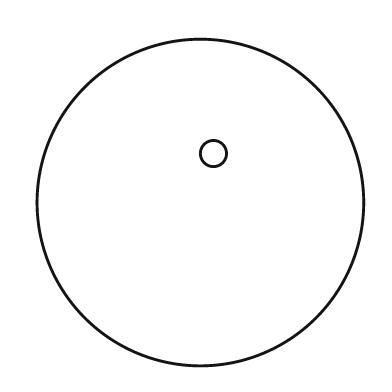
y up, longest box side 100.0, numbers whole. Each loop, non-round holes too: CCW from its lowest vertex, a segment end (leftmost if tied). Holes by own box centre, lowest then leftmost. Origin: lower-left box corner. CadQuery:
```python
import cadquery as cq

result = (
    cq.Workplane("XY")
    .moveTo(50.0, 50.0)
    .circle(50.0)
    .moveTo(54.0, 65.0)
    .circle(4.0)
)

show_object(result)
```